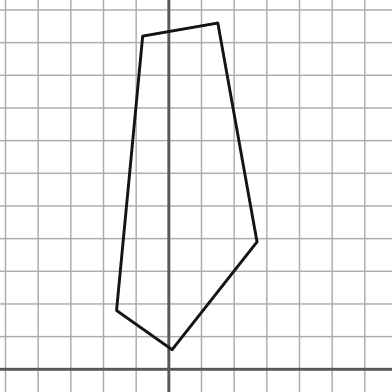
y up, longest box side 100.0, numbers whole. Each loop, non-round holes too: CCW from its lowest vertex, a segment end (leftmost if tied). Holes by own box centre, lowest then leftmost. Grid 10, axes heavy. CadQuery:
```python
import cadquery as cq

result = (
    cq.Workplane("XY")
    .moveTo(1.0, 6.0)
    .lineTo(27.0, 39.0)
    .lineTo(15.0, 106.0)
    .lineTo(-8.0, 102.0)
    .lineTo(-16.0, 18.0)
    .close()
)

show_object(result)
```